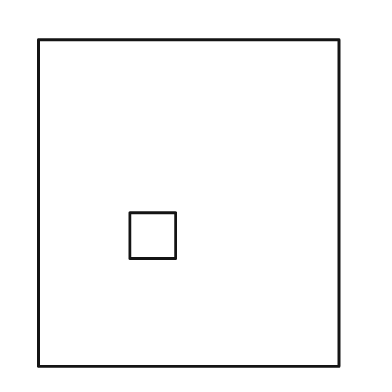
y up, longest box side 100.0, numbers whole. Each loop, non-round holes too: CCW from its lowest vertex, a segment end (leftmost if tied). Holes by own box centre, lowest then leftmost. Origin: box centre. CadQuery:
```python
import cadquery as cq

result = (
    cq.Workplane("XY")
    .moveTo(-46.0, -50.0)
    .lineTo(46.0, -50.0)
    .lineTo(46.0, 50.0)
    .lineTo(-46.0, 50.0)
    .close()
    .moveTo(-18.0, -17.0)
    .lineTo(-4.0, -17.0)
    .lineTo(-4.0, -3.0)
    .lineTo(-18.0, -3.0)
    .close()
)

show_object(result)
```